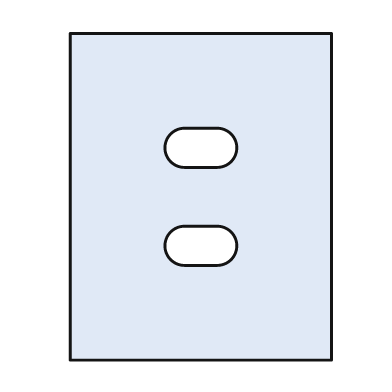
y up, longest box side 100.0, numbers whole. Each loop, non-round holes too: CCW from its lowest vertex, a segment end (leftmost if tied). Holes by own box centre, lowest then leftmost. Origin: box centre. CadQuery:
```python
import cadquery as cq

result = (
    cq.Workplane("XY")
    .moveTo(-40.0, -50.0)
    .lineTo(40.0, -50.0)
    .lineTo(40.0, 50.0)
    .lineTo(-40.0, 50.0)
    .close()
    .moveTo(-5.0, -21.0)
    .lineTo(5.0, -21.0)
    .threePointArc((11.0, -15.0), (5.0, -9.0))
    .lineTo(-5.0, -9.0)
    .threePointArc((-11.0, -15.0), (-5.0, -21.0))
    .close()
    .moveTo(-5.0, 9.0)
    .lineTo(5.0, 9.0)
    .threePointArc((11.0, 15.0), (5.0, 21.0))
    .lineTo(-5.0, 21.0)
    .threePointArc((-11.0, 15.0), (-5.0, 9.0))
    .close()
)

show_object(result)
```